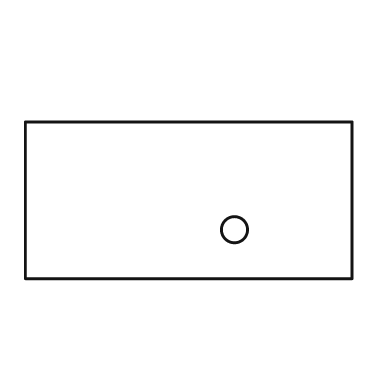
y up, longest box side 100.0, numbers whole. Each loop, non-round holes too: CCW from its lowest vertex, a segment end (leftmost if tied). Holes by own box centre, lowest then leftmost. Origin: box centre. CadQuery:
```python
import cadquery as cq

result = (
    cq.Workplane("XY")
    .moveTo(-50.0, -24.0)
    .lineTo(50.0, -24.0)
    .lineTo(50.0, 24.0)
    .lineTo(-50.0, 24.0)
    .close()
    .moveTo(14.0, -9.0)
    .circle(4.0)
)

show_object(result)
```